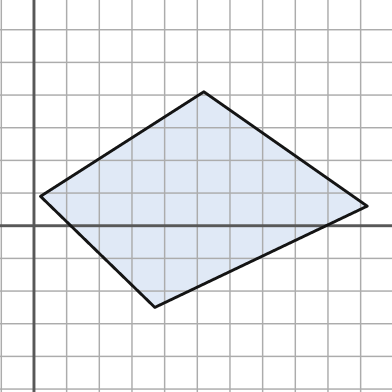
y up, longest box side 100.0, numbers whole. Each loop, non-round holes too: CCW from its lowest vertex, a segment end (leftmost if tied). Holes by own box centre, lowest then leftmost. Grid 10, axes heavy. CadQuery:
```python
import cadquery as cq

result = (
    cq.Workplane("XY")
    .moveTo(37.0, -25.0)
    .lineTo(102.0, 6.0)
    .lineTo(52.0, 41.0)
    .lineTo(2.0, 9.0)
    .close()
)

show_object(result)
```